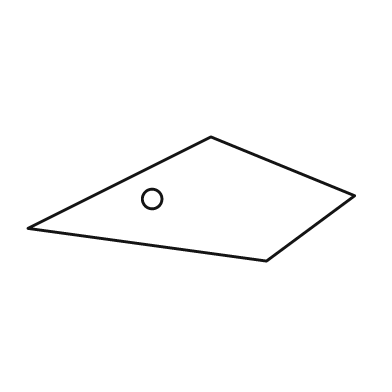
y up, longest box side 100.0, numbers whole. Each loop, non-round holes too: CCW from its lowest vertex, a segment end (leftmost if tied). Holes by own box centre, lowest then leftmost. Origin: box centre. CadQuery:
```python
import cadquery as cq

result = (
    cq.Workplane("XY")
    .moveTo(23.0, -19.0)
    .lineTo(50.0, 1.0)
    .lineTo(6.0, 19.0)
    .lineTo(-50.0, -9.0)
    .close()
    .moveTo(-12.0, 0.0)
    .circle(3.0)
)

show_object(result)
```